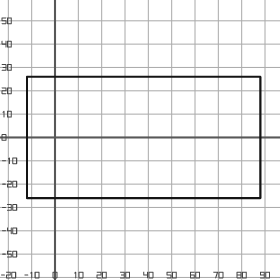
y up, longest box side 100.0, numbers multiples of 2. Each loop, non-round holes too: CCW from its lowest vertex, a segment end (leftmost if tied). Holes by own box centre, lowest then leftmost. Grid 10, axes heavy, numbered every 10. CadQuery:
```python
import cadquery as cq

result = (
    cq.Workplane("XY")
    .moveTo(-12.0, -26.0)
    .lineTo(88.0, -26.0)
    .lineTo(88.0, 26.0)
    .lineTo(-12.0, 26.0)
    .close()
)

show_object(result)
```